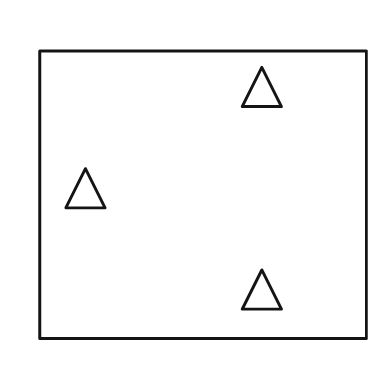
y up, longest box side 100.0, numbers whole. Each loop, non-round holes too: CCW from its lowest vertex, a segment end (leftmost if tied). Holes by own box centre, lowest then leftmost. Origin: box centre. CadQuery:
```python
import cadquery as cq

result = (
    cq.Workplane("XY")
    .moveTo(-50.0, -44.0)
    .lineTo(50.0, -44.0)
    .lineTo(50.0, 44.0)
    .lineTo(-50.0, 44.0)
    .close()
    .moveTo(12.0, -35.0)
    .lineTo(24.0, -35.0)
    .lineTo(18.0, -23.0)
    .close()
    .moveTo(-42.0, -4.0)
    .lineTo(-30.0, -4.0)
    .lineTo(-36.0, 8.0)
    .close()
    .moveTo(12.0, 27.0)
    .lineTo(24.0, 27.0)
    .lineTo(18.0, 39.0)
    .close()
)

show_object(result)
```